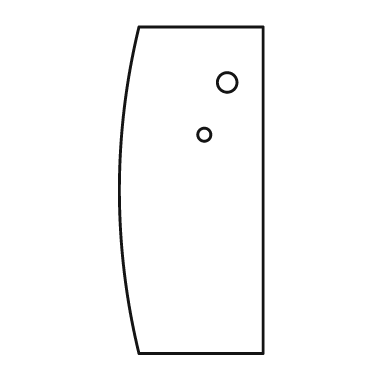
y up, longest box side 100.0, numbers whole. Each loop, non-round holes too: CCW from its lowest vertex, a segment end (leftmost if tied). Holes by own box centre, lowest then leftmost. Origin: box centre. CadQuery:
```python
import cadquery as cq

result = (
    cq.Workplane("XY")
    .moveTo(-16.0, -50.0)
    .lineTo(22.0, -50.0)
    .lineTo(22.0, 50.0)
    .lineTo(-16.0, 50.0)
    .threePointArc((-22.0, 0.0), (-16.0, -50.0))
    .close()
    .moveTo(4.0, 17.0)
    .circle(2.0)
    .moveTo(11.0, 33.0)
    .circle(3.0)
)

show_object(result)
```